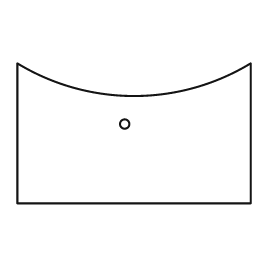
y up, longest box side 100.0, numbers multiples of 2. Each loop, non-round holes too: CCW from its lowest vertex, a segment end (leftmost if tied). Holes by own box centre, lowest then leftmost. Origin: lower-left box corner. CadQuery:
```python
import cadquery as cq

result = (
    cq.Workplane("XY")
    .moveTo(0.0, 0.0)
    .lineTo(100.0, 0.0)
    .lineTo(100.0, 60.0)
    .threePointArc((50.0, 46.0), (0.0, 60.0))
    .close()
    .moveTo(46.0, 34.0)
    .circle(2.0)
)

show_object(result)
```